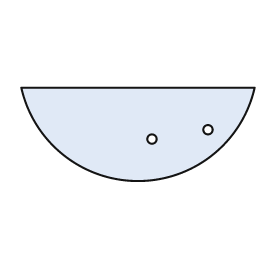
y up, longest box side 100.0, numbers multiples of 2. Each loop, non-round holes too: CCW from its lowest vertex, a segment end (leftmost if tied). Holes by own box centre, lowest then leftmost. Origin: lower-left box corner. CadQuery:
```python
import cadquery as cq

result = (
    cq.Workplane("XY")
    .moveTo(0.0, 40.0)
    .threePointArc((50.0, 0.0), (100.0, 40.0))
    .close()
    .moveTo(56.0, 18.0)
    .circle(2.0)
    .moveTo(80.0, 22.0)
    .circle(2.0)
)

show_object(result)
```